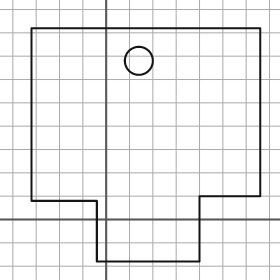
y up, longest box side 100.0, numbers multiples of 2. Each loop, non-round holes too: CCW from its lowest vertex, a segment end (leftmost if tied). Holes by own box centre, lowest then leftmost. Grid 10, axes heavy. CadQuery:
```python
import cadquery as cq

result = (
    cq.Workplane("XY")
    .moveTo(-4.0, -18.0)
    .lineTo(40.0, -18.0)
    .lineTo(40.0, 10.0)
    .lineTo(66.0, 10.0)
    .lineTo(66.0, 82.0)
    .lineTo(-32.0, 82.0)
    .lineTo(-32.0, 8.0)
    .lineTo(-4.0, 8.0)
    .close()
    .moveTo(14.0, 68.0)
    .circle(6.0)
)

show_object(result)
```